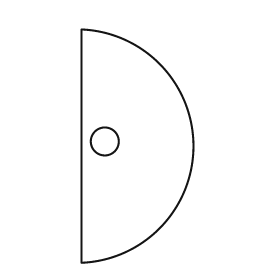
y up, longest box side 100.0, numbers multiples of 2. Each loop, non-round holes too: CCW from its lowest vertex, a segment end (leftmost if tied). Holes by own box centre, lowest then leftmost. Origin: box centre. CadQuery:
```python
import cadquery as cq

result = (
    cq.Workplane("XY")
    .moveTo(-24.0, -50.0)
    .threePointArc((24.0, 0.0), (-24.0, 50.0))
    .close()
    .moveTo(-14.0, 2.0)
    .circle(6.0)
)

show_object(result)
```